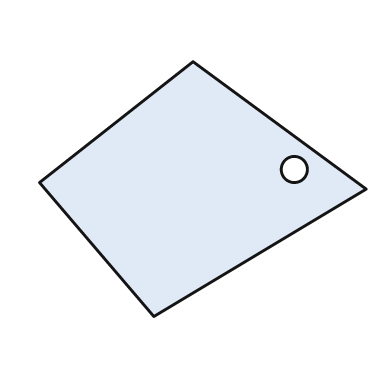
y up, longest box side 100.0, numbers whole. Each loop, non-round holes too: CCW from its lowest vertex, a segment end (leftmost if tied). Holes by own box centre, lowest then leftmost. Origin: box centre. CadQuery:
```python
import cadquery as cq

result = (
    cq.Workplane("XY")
    .moveTo(-15.0, -39.0)
    .lineTo(50.0, 0.0)
    .lineTo(-3.0, 39.0)
    .lineTo(-50.0, 2.0)
    .close()
    .moveTo(28.0, 6.0)
    .circle(4.0)
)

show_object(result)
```